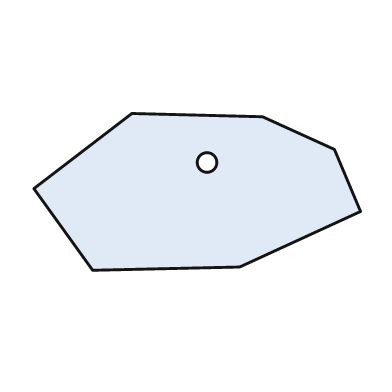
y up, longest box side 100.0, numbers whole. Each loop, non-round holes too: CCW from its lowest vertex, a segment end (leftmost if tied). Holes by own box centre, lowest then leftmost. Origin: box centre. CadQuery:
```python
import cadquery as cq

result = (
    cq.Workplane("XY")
    .moveTo(-32.0, -24.0)
    .lineTo(13.0, -23.0)
    .lineTo(50.0, -6.0)
    .lineTo(42.0, 13.0)
    .lineTo(20.0, 23.0)
    .lineTo(-20.0, 24.0)
    .lineTo(-50.0, 1.0)
    .close()
    .moveTo(3.0, 9.0)
    .circle(3.0)
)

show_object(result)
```